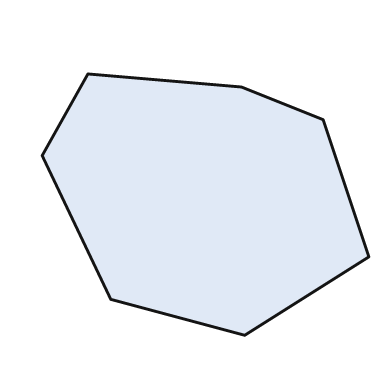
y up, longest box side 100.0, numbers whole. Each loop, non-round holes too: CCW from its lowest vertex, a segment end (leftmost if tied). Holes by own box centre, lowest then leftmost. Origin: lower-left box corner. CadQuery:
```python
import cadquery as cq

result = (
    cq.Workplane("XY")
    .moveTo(62.0, 0.0)
    .lineTo(100.0, 24.0)
    .lineTo(86.0, 66.0)
    .lineTo(61.0, 76.0)
    .lineTo(14.0, 80.0)
    .lineTo(0.0, 55.0)
    .lineTo(21.0, 11.0)
    .close()
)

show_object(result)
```